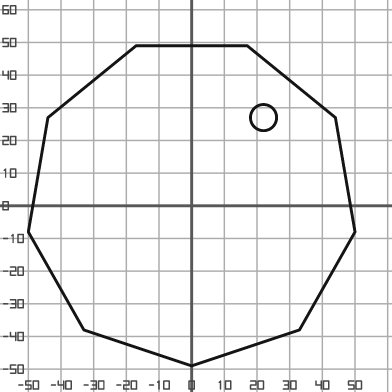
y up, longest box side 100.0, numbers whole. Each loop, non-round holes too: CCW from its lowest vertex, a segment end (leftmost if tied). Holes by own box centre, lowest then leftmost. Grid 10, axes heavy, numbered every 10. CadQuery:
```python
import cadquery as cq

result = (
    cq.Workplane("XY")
    .moveTo(0.0, -49.0)
    .lineTo(33.0, -38.0)
    .lineTo(50.0, -8.0)
    .lineTo(44.0, 27.0)
    .lineTo(17.0, 49.0)
    .lineTo(-17.0, 49.0)
    .lineTo(-44.0, 27.0)
    .lineTo(-50.0, -8.0)
    .lineTo(-33.0, -38.0)
    .close()
    .moveTo(22.0, 27.0)
    .circle(4.0)
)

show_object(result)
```